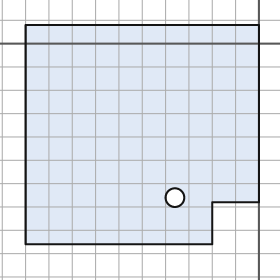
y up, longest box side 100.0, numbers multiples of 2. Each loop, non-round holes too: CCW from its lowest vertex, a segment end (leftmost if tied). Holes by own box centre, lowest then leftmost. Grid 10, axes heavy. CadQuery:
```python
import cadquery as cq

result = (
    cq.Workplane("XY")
    .moveTo(-100.0, -86.0)
    .lineTo(-20.0, -86.0)
    .lineTo(-20.0, -68.0)
    .lineTo(0.0, -68.0)
    .lineTo(0.0, 8.0)
    .lineTo(-100.0, 8.0)
    .close()
    .moveTo(-36.0, -66.0)
    .circle(4.0)
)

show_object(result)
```